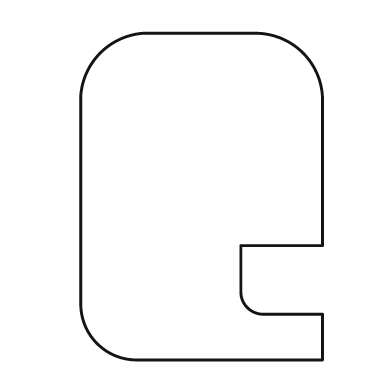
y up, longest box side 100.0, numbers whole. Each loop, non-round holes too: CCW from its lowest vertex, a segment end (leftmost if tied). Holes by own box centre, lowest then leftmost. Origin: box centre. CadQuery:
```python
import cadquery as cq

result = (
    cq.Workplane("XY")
    .moveTo(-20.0, -50.0)
    .lineTo(37.0, -50.0)
    .lineTo(37.0, -36.0)
    .lineTo(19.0, -36.0)
    .threePointArc((14.0, -34.0), (12.0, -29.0))
    .lineTo(12.0, -15.0)
    .lineTo(37.0, -15.0)
    .lineTo(37.0, 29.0)
    .threePointArc((31.0, 44.0), (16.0, 50.0))
    .lineTo(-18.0, 50.0)
    .threePointArc((-31.0, 44.0), (-37.0, 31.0))
    .lineTo(-37.0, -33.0)
    .threePointArc((-32.0, -45.0), (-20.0, -50.0))
    .close()
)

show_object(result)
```